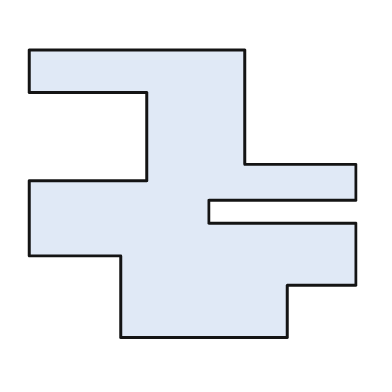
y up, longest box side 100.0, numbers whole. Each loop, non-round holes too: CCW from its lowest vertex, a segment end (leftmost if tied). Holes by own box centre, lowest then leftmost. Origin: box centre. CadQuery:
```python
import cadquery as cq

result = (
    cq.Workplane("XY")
    .moveTo(-22.0, -44.0)
    .lineTo(29.0, -44.0)
    .lineTo(29.0, -28.0)
    .lineTo(50.0, -28.0)
    .lineTo(50.0, -9.0)
    .lineTo(5.0, -9.0)
    .lineTo(5.0, -2.0)
    .lineTo(50.0, -2.0)
    .lineTo(50.0, 9.0)
    .lineTo(16.0, 9.0)
    .lineTo(16.0, 44.0)
    .lineTo(-50.0, 44.0)
    .lineTo(-50.0, 31.0)
    .lineTo(-14.0, 31.0)
    .lineTo(-14.0, 4.0)
    .lineTo(-50.0, 4.0)
    .lineTo(-50.0, -19.0)
    .lineTo(-22.0, -19.0)
    .close()
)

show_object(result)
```